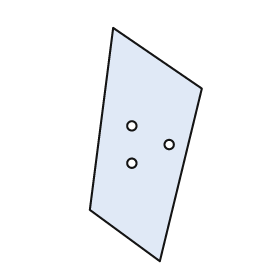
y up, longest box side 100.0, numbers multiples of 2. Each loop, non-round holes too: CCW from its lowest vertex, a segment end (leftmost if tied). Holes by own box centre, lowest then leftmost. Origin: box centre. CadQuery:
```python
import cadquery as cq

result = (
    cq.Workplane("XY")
    .moveTo(6.0, -50.0)
    .lineTo(24.0, 24.0)
    .lineTo(-14.0, 50.0)
    .lineTo(-24.0, -28.0)
    .close()
    .moveTo(-6.0, -8.0)
    .circle(2.0)
    .moveTo(10.0, 0.0)
    .circle(2.0)
    .moveTo(-6.0, 8.0)
    .circle(2.0)
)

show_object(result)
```